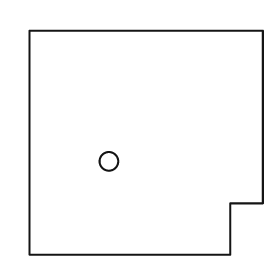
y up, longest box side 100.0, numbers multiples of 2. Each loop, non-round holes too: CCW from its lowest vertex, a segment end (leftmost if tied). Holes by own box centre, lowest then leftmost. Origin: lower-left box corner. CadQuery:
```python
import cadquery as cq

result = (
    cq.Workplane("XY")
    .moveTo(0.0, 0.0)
    .lineTo(86.0, 0.0)
    .lineTo(86.0, 22.0)
    .lineTo(100.0, 22.0)
    .lineTo(100.0, 96.0)
    .lineTo(0.0, 96.0)
    .close()
    .moveTo(34.0, 40.0)
    .circle(4.0)
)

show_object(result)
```